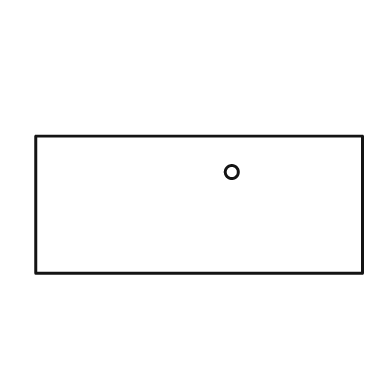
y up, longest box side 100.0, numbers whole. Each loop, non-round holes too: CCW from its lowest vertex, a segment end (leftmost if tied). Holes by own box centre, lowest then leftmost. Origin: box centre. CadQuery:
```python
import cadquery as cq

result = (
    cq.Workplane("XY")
    .moveTo(-50.0, -21.0)
    .lineTo(50.0, -21.0)
    .lineTo(50.0, 21.0)
    .lineTo(-50.0, 21.0)
    .close()
    .moveTo(10.0, 10.0)
    .circle(2.0)
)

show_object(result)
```